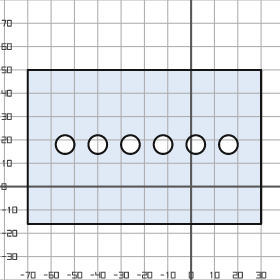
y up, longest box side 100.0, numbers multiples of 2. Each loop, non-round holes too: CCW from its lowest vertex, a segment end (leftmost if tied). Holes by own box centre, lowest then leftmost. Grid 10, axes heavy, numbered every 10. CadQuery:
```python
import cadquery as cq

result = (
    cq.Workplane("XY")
    .moveTo(-70.0, -16.0)
    .lineTo(30.0, -16.0)
    .lineTo(30.0, 50.0)
    .lineTo(-70.0, 50.0)
    .close()
    .moveTo(-54.0, 18.0)
    .circle(4.0)
    .moveTo(-40.0, 18.0)
    .circle(4.0)
    .moveTo(-26.0, 18.0)
    .circle(4.0)
    .moveTo(-12.0, 18.0)
    .circle(4.0)
    .moveTo(2.0, 18.0)
    .circle(4.0)
    .moveTo(16.0, 18.0)
    .circle(4.0)
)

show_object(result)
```